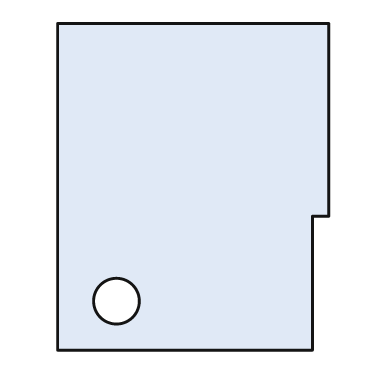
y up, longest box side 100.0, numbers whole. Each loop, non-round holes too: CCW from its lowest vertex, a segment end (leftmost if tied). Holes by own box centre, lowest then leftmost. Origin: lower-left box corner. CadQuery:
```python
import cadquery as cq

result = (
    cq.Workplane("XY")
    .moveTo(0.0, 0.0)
    .lineTo(78.0, 0.0)
    .lineTo(78.0, 41.0)
    .lineTo(83.0, 41.0)
    .lineTo(83.0, 100.0)
    .lineTo(0.0, 100.0)
    .close()
    .moveTo(18.0, 15.0)
    .circle(7.0)
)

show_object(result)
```